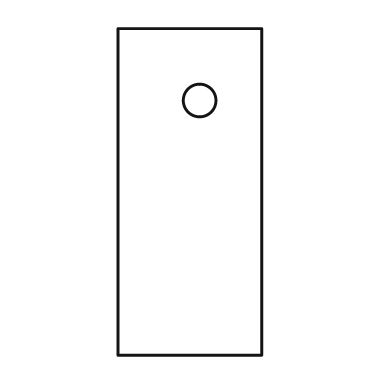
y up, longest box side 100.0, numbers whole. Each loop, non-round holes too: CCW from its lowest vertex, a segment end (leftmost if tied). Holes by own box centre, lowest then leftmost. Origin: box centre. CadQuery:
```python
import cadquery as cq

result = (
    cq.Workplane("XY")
    .moveTo(-22.0, -50.0)
    .lineTo(22.0, -50.0)
    .lineTo(22.0, 50.0)
    .lineTo(-22.0, 50.0)
    .close()
    .moveTo(3.0, 28.0)
    .circle(5.0)
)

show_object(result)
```